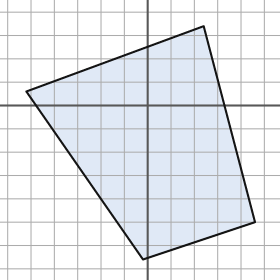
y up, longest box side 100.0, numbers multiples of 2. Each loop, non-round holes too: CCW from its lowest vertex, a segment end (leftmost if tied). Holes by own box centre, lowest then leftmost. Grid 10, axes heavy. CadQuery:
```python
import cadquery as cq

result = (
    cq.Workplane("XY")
    .moveTo(-2.0, -66.0)
    .lineTo(46.0, -50.0)
    .lineTo(24.0, 34.0)
    .lineTo(-52.0, 6.0)
    .close()
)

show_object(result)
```